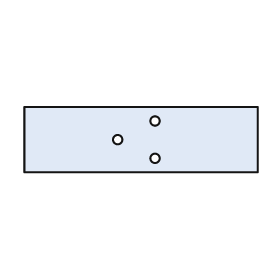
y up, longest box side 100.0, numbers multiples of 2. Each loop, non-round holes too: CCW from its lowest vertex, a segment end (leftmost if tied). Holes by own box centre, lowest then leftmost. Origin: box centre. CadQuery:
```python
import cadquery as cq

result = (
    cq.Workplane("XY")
    .moveTo(-50.0, -14.0)
    .lineTo(50.0, -14.0)
    .lineTo(50.0, 14.0)
    .lineTo(-50.0, 14.0)
    .close()
    .moveTo(6.0, -8.0)
    .circle(2.0)
    .moveTo(-10.0, 0.0)
    .circle(2.0)
    .moveTo(6.0, 8.0)
    .circle(2.0)
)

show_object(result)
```